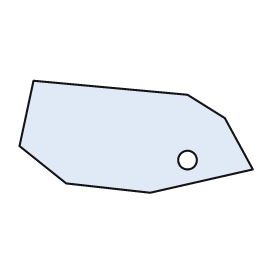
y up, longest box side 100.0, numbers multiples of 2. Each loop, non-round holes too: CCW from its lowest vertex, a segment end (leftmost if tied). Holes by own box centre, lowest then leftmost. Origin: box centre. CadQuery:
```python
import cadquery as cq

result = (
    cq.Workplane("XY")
    .moveTo(6.0, -24.0)
    .lineTo(50.0, -14.0)
    .lineTo(38.0, 8.0)
    .lineTo(22.0, 18.0)
    .lineTo(-44.0, 24.0)
    .lineTo(-50.0, -4.0)
    .lineTo(-30.0, -20.0)
    .close()
    .moveTo(22.0, -10.0)
    .circle(4.0)
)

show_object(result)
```